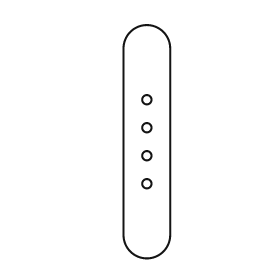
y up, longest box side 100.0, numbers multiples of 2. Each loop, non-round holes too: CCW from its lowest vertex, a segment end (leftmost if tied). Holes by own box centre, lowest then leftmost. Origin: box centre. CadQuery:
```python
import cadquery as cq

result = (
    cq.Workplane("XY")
    .moveTo(-10.0, -40.0)
    .threePointArc((0.0, -50.0), (10.0, -40.0))
    .lineTo(10.0, 40.0)
    .threePointArc((0.0, 50.0), (-10.0, 40.0))
    .close()
    .moveTo(0.0, -18.0)
    .circle(2.0)
    .moveTo(0.0, -6.0)
    .circle(2.0)
    .moveTo(0.0, 6.0)
    .circle(2.0)
    .moveTo(0.0, 18.0)
    .circle(2.0)
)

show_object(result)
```